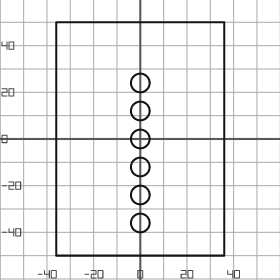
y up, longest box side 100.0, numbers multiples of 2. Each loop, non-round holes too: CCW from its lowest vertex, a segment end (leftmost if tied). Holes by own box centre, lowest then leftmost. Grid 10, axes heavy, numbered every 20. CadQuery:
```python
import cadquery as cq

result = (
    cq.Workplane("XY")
    .moveTo(-36.0, -50.0)
    .lineTo(36.0, -50.0)
    .lineTo(36.0, 50.0)
    .lineTo(-36.0, 50.0)
    .close()
    .moveTo(0.0, -36.0)
    .circle(4.0)
    .moveTo(0.0, -24.0)
    .circle(4.0)
    .moveTo(0.0, -12.0)
    .circle(4.0)
    .moveTo(0.0, 0.0)
    .circle(4.0)
    .moveTo(0.0, 12.0)
    .circle(4.0)
    .moveTo(0.0, 24.0)
    .circle(4.0)
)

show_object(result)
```